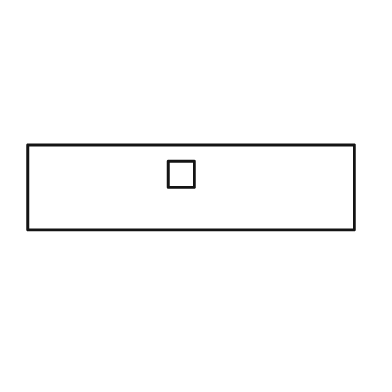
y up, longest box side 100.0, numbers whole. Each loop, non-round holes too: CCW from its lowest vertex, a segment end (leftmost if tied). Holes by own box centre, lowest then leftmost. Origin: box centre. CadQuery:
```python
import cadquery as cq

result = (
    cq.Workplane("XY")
    .moveTo(-50.0, -13.0)
    .lineTo(50.0, -13.0)
    .lineTo(50.0, 13.0)
    .lineTo(-50.0, 13.0)
    .close()
    .moveTo(-7.0, 0.0)
    .lineTo(1.0, 0.0)
    .lineTo(1.0, 8.0)
    .lineTo(-7.0, 8.0)
    .close()
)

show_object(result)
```